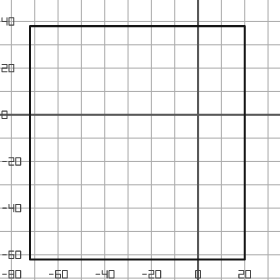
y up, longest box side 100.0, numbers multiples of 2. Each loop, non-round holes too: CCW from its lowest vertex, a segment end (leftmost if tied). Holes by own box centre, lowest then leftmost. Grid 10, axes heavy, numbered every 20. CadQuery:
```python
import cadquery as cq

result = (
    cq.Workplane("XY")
    .moveTo(-72.0, -62.0)
    .lineTo(20.0, -62.0)
    .lineTo(20.0, 38.0)
    .lineTo(-72.0, 38.0)
    .close()
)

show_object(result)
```